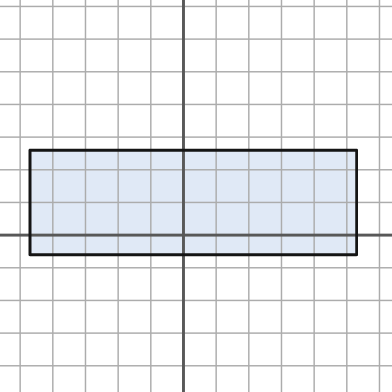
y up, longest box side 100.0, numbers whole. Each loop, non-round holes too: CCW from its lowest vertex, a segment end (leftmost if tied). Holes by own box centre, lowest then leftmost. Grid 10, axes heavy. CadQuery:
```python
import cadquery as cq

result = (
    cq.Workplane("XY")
    .moveTo(-47.0, -6.0)
    .lineTo(53.0, -6.0)
    .lineTo(53.0, 26.0)
    .lineTo(-47.0, 26.0)
    .close()
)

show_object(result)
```